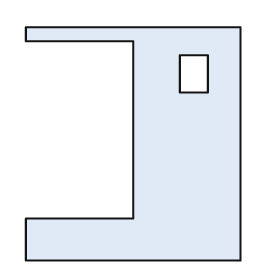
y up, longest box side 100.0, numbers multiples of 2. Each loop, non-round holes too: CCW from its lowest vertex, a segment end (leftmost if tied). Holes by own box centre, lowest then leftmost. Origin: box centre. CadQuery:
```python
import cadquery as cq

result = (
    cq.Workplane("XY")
    .moveTo(-46.0, -50.0)
    .lineTo(46.0, -50.0)
    .lineTo(46.0, 50.0)
    .lineTo(-46.0, 50.0)
    .lineTo(-46.0, 44.0)
    .lineTo(0.0, 44.0)
    .lineTo(0.0, -32.0)
    .lineTo(-46.0, -32.0)
    .close()
    .moveTo(20.0, 22.0)
    .lineTo(32.0, 22.0)
    .lineTo(32.0, 38.0)
    .lineTo(20.0, 38.0)
    .close()
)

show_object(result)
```